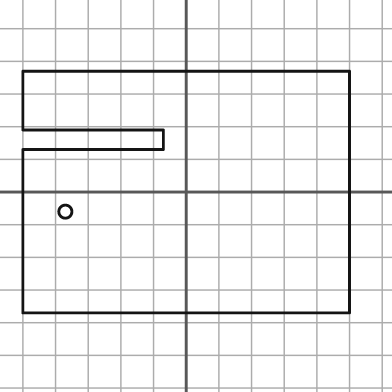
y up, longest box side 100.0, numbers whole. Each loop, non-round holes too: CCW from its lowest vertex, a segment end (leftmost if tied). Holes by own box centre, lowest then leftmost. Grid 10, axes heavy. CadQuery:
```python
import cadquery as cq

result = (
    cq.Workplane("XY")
    .moveTo(-50.0, -37.0)
    .lineTo(50.0, -37.0)
    .lineTo(50.0, 37.0)
    .lineTo(-50.0, 37.0)
    .lineTo(-50.0, 19.0)
    .lineTo(-7.0, 19.0)
    .lineTo(-7.0, 13.0)
    .lineTo(-50.0, 13.0)
    .close()
    .moveTo(-37.0, -6.0)
    .circle(2.0)
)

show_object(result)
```